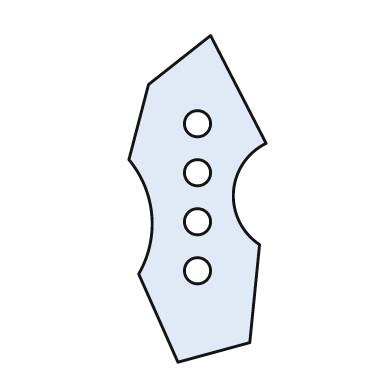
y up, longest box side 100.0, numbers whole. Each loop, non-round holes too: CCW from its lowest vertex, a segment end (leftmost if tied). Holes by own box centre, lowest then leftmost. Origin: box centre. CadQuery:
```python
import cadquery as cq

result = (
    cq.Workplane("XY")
    .moveTo(-6.0, -50.0)
    .lineTo(16.0, -44.0)
    .lineTo(19.0, -14.0)
    .threePointArc((11.0, 2.0), (21.0, 17.0))
    .lineTo(4.0, 50.0)
    .lineTo(-15.0, 35.0)
    .lineTo(-21.0, 12.0)
    .threePointArc((-14.0, -5.0), (-18.0, -23.0))
    .close()
    .moveTo(0.0, -22.0)
    .circle(4.0)
    .moveTo(0.0, -7.0)
    .circle(4.0)
    .moveTo(0.0, 8.0)
    .circle(4.0)
    .moveTo(0.0, 23.0)
    .circle(4.0)
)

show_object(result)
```